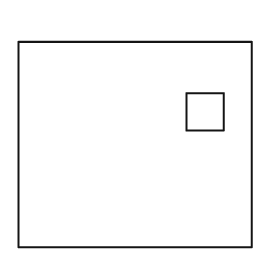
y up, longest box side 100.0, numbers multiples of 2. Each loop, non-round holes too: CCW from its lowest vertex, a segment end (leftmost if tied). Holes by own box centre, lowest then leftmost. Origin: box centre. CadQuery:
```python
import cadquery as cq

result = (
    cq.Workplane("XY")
    .moveTo(-50.0, -44.0)
    .lineTo(50.0, -44.0)
    .lineTo(50.0, 44.0)
    .lineTo(-50.0, 44.0)
    .close()
    .moveTo(22.0, 6.0)
    .lineTo(38.0, 6.0)
    .lineTo(38.0, 22.0)
    .lineTo(22.0, 22.0)
    .close()
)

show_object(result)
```